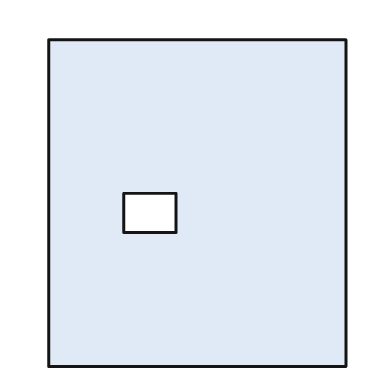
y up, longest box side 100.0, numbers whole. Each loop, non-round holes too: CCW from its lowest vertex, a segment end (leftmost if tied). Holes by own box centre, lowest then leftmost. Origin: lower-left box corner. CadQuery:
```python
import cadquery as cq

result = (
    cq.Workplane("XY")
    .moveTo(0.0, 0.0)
    .lineTo(91.0, 0.0)
    .lineTo(91.0, 100.0)
    .lineTo(0.0, 100.0)
    .close()
    .moveTo(23.0, 41.0)
    .lineTo(39.0, 41.0)
    .lineTo(39.0, 53.0)
    .lineTo(23.0, 53.0)
    .close()
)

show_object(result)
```